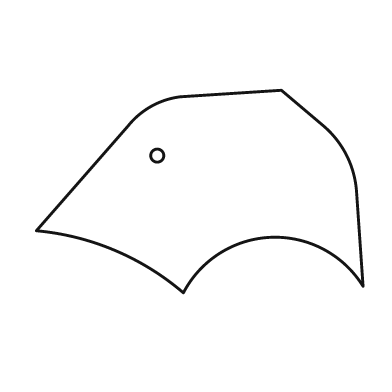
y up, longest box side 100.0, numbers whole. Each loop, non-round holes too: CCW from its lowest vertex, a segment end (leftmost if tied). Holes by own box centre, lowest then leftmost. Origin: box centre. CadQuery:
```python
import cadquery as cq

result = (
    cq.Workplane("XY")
    .moveTo(-5.0, -31.0)
    .threePointArc((22.0, -14.0), (50.0, -29.0))
    .lineTo(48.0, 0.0)
    .threePointArc((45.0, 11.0), (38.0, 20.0))
    .lineTo(25.0, 31.0)
    .lineTo(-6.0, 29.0)
    .threePointArc((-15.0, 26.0), (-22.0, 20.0))
    .lineTo(-50.0, -12.0)
    .threePointArc((-26.0, -18.0), (-5.0, -31.0))
    .close()
    .moveTo(-13.0, 11.0)
    .circle(2.0)
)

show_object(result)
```